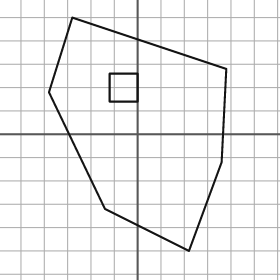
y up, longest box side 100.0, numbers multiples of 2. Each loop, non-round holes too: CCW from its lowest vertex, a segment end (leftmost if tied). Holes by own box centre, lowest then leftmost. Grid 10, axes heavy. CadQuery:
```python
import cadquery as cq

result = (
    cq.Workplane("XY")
    .moveTo(22.0, -50.0)
    .lineTo(36.0, -12.0)
    .lineTo(38.0, 28.0)
    .lineTo(-28.0, 50.0)
    .lineTo(-38.0, 18.0)
    .lineTo(-14.0, -32.0)
    .close()
    .moveTo(-12.0, 14.0)
    .lineTo(0.0, 14.0)
    .lineTo(0.0, 26.0)
    .lineTo(-12.0, 26.0)
    .close()
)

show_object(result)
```